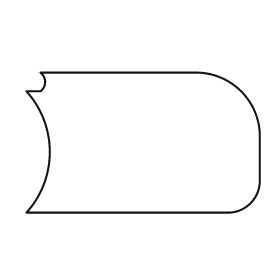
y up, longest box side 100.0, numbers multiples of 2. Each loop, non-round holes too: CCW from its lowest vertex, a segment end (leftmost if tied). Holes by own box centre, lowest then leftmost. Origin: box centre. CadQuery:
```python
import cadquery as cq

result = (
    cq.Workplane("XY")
    .moveTo(-50.0, -30.0)
    .lineTo(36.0, -30.0)
    .threePointArc((46.0, -26.0), (50.0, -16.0))
    .lineTo(50.0, 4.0)
    .threePointArc((42.0, 22.0), (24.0, 30.0))
    .lineTo(-44.0, 30.0)
    .threePointArc((-42.0, 26.0), (-44.0, 22.0))
    .lineTo(-50.0, 22.0)
    .threePointArc((-40.0, -4.0), (-50.0, -30.0))
    .close()
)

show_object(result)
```